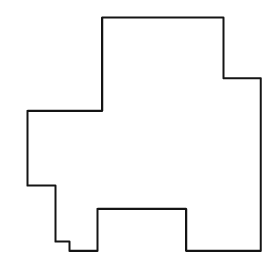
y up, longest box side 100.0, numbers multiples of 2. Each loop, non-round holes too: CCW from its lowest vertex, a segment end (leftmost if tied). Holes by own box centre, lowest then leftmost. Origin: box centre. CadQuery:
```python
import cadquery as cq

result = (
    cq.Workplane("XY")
    .moveTo(-32.0, -50.0)
    .lineTo(-20.0, -50.0)
    .lineTo(-20.0, -32.0)
    .lineTo(18.0, -32.0)
    .lineTo(18.0, -50.0)
    .lineTo(50.0, -50.0)
    .lineTo(50.0, 24.0)
    .lineTo(34.0, 24.0)
    .lineTo(34.0, 50.0)
    .lineTo(-18.0, 50.0)
    .lineTo(-18.0, 10.0)
    .lineTo(-50.0, 10.0)
    .lineTo(-50.0, -22.0)
    .lineTo(-38.0, -22.0)
    .lineTo(-38.0, -46.0)
    .lineTo(-32.0, -46.0)
    .close()
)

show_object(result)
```